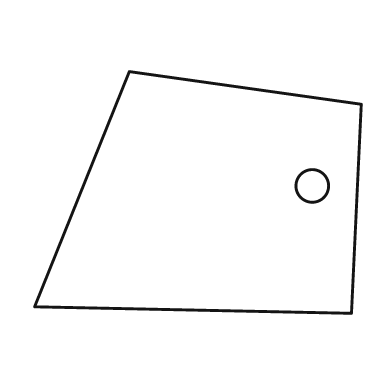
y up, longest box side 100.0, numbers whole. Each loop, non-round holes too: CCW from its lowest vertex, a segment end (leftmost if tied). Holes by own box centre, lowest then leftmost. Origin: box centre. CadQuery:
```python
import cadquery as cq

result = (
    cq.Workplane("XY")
    .moveTo(47.0, -37.0)
    .lineTo(50.0, 27.0)
    .lineTo(-21.0, 37.0)
    .lineTo(-50.0, -35.0)
    .close()
    .moveTo(35.0, 2.0)
    .circle(5.0)
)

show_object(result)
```